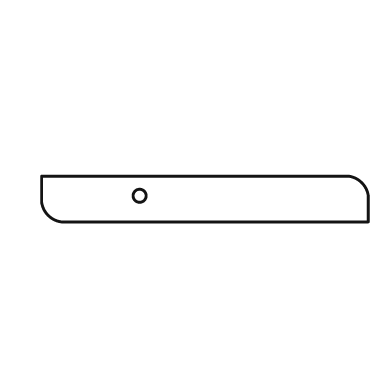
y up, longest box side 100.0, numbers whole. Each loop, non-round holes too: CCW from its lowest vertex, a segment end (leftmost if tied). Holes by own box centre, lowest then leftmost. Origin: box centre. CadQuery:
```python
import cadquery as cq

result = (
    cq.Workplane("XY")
    .moveTo(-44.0, -7.0)
    .lineTo(50.0, -7.0)
    .lineTo(50.0, 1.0)
    .threePointArc((48.0, 5.0), (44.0, 7.0))
    .lineTo(-50.0, 7.0)
    .lineTo(-50.0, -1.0)
    .threePointArc((-48.0, -5.0), (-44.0, -7.0))
    .close()
    .moveTo(-20.0, 1.0)
    .circle(2.0)
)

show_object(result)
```